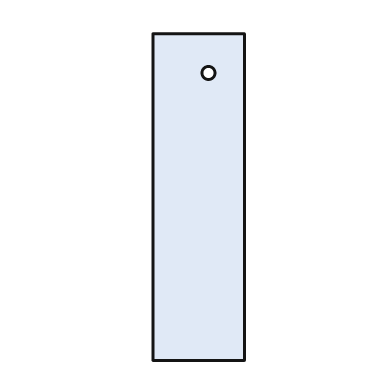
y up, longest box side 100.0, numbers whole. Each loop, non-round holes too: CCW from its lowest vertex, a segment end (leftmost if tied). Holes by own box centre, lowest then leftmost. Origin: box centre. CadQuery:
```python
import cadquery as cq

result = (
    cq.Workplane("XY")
    .moveTo(-14.0, -50.0)
    .lineTo(14.0, -50.0)
    .lineTo(14.0, 50.0)
    .lineTo(-14.0, 50.0)
    .close()
    .moveTo(3.0, 38.0)
    .circle(2.0)
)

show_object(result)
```